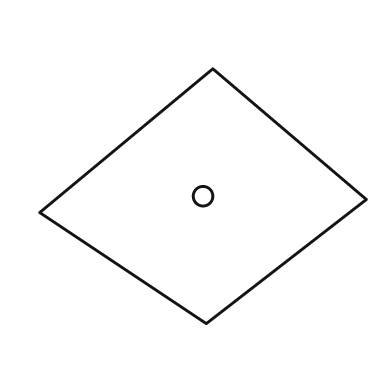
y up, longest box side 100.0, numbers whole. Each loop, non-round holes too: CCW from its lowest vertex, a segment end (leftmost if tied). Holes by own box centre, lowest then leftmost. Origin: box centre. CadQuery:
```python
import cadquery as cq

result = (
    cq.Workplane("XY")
    .moveTo(1.0, -39.0)
    .lineTo(50.0, -1.0)
    .lineTo(3.0, 39.0)
    .lineTo(-50.0, -5.0)
    .close()
    .moveTo(0.0, 0.0)
    .circle(3.0)
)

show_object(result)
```